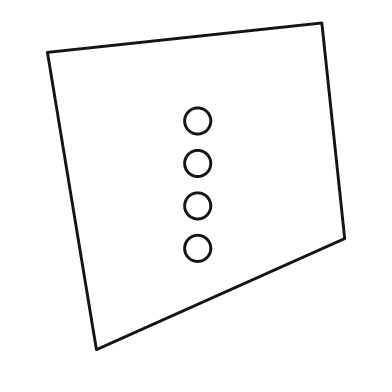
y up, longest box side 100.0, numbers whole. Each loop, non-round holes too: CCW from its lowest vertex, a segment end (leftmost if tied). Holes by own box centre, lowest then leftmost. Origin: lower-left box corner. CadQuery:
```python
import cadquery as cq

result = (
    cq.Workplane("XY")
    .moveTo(15.0, 0.0)
    .lineTo(91.0, 34.0)
    .lineTo(84.0, 100.0)
    .lineTo(0.0, 91.0)
    .close()
    .moveTo(46.0, 31.0)
    .circle(4.0)
    .moveTo(46.0, 44.0)
    .circle(4.0)
    .moveTo(46.0, 57.0)
    .circle(4.0)
    .moveTo(46.0, 70.0)
    .circle(4.0)
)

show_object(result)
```